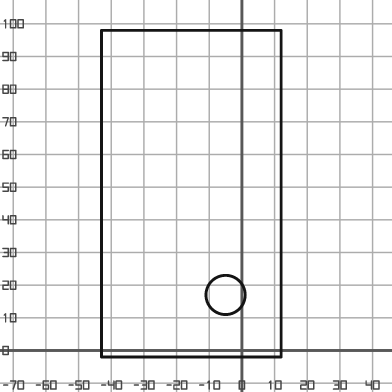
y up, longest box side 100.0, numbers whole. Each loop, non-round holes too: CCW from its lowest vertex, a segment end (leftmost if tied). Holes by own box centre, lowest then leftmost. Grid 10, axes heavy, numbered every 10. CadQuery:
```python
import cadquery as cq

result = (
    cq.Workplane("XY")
    .moveTo(-43.0, -2.0)
    .lineTo(12.0, -2.0)
    .lineTo(12.0, 98.0)
    .lineTo(-43.0, 98.0)
    .close()
    .moveTo(-5.0, 17.0)
    .circle(6.0)
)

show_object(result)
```